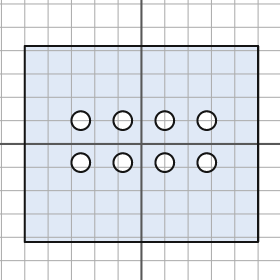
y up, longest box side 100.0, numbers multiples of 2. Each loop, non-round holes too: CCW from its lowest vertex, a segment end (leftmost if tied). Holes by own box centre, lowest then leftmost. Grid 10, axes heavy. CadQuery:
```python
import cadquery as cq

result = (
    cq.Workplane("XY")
    .moveTo(-50.0, -42.0)
    .lineTo(50.0, -42.0)
    .lineTo(50.0, 42.0)
    .lineTo(-50.0, 42.0)
    .close()
    .moveTo(-26.0, -8.0)
    .circle(4.0)
    .moveTo(-8.0, -8.0)
    .circle(4.0)
    .moveTo(10.0, -8.0)
    .circle(4.0)
    .moveTo(28.0, -8.0)
    .circle(4.0)
    .moveTo(-26.0, 10.0)
    .circle(4.0)
    .moveTo(-8.0, 10.0)
    .circle(4.0)
    .moveTo(10.0, 10.0)
    .circle(4.0)
    .moveTo(28.0, 10.0)
    .circle(4.0)
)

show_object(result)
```